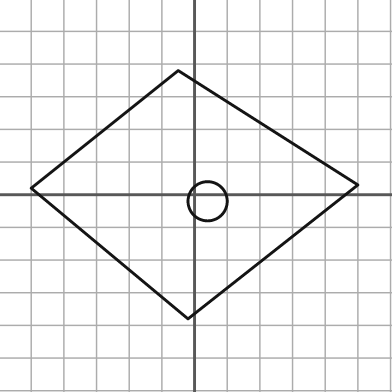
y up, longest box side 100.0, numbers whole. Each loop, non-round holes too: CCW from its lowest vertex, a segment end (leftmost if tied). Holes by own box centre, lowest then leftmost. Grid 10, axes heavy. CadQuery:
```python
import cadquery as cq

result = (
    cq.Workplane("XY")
    .moveTo(-2.0, -38.0)
    .lineTo(50.0, 3.0)
    .lineTo(-5.0, 38.0)
    .lineTo(-50.0, 2.0)
    .close()
    .moveTo(4.0, -2.0)
    .circle(6.0)
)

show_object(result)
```